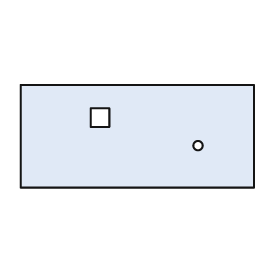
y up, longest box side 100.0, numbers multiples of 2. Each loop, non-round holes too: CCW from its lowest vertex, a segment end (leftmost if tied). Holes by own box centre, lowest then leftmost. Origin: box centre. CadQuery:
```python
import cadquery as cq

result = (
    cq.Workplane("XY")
    .moveTo(-50.0, -22.0)
    .lineTo(50.0, -22.0)
    .lineTo(50.0, 22.0)
    .lineTo(-50.0, 22.0)
    .close()
    .moveTo(26.0, -4.0)
    .circle(2.0)
    .moveTo(-20.0, 4.0)
    .lineTo(-12.0, 4.0)
    .lineTo(-12.0, 12.0)
    .lineTo(-20.0, 12.0)
    .close()
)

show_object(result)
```